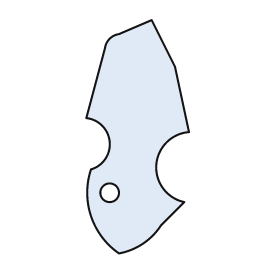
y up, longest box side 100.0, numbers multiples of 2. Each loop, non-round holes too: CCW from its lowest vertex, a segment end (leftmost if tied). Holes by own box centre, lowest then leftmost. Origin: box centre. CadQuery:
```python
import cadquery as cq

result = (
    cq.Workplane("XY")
    .moveTo(-8.0, -50.0)
    .threePointArc((2.0, -46.0), (10.0, -38.0))
    .lineTo(20.0, -28.0)
    .threePointArc((8.0, -12.0), (22.0, 2.0))
    .lineTo(16.0, 30.0)
    .lineTo(6.0, 50.0)
    .lineTo(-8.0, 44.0)
    .threePointArc((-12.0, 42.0), (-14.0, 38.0))
    .lineTo(-22.0, 8.0)
    .threePointArc((-12.0, -2.0), (-20.0, -14.0))
    .threePointArc((-20.0, -34.0), (-8.0, -50.0))
    .close()
    .moveTo(-12.0, -24.0)
    .circle(4.0)
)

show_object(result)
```